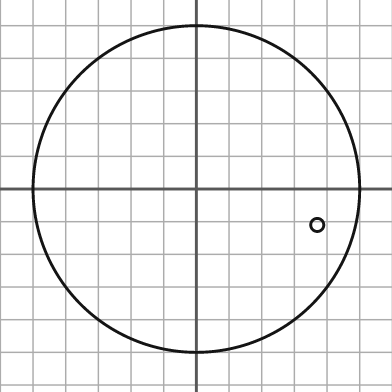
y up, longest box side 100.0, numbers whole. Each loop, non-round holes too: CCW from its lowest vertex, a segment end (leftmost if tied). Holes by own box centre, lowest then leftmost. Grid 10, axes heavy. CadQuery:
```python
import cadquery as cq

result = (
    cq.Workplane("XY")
    .moveTo(0.0, 0.0)
    .circle(50.0)
    .moveTo(37.0, -11.0)
    .circle(2.0)
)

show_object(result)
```